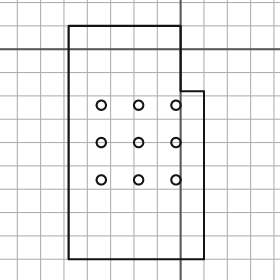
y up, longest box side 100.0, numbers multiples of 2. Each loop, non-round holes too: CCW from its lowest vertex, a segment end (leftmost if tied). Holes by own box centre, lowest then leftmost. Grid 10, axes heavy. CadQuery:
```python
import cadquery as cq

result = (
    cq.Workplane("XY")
    .moveTo(-48.0, -90.0)
    .lineTo(10.0, -90.0)
    .lineTo(10.0, -18.0)
    .lineTo(0.0, -18.0)
    .lineTo(0.0, 10.0)
    .lineTo(-48.0, 10.0)
    .close()
    .moveTo(-34.0, -56.0)
    .circle(2.0)
    .moveTo(-18.0, -56.0)
    .circle(2.0)
    .moveTo(-2.0, -56.0)
    .circle(2.0)
    .moveTo(-34.0, -40.0)
    .circle(2.0)
    .moveTo(-18.0, -40.0)
    .circle(2.0)
    .moveTo(-2.0, -40.0)
    .circle(2.0)
    .moveTo(-34.0, -24.0)
    .circle(2.0)
    .moveTo(-18.0, -24.0)
    .circle(2.0)
    .moveTo(-2.0, -24.0)
    .circle(2.0)
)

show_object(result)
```